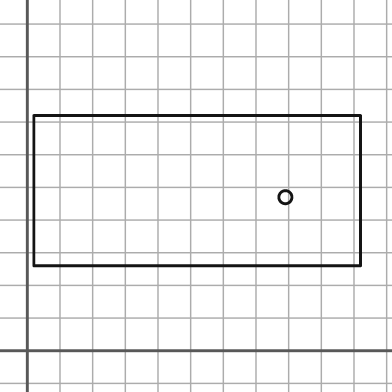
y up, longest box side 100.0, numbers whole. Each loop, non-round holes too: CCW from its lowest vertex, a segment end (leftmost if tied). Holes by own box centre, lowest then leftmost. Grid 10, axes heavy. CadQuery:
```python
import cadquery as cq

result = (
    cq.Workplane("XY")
    .moveTo(2.0, 26.0)
    .lineTo(102.0, 26.0)
    .lineTo(102.0, 72.0)
    .lineTo(2.0, 72.0)
    .close()
    .moveTo(79.0, 47.0)
    .circle(2.0)
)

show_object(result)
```